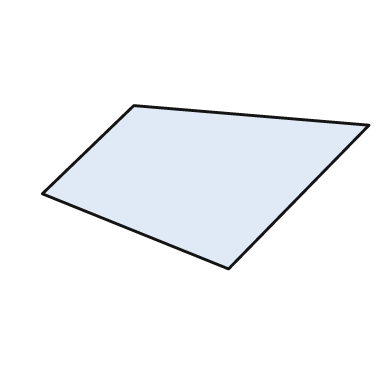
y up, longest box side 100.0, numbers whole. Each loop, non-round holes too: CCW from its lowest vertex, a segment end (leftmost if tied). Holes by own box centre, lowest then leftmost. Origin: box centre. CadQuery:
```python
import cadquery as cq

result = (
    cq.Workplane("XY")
    .moveTo(7.0, -25.0)
    .lineTo(50.0, 19.0)
    .lineTo(-22.0, 25.0)
    .lineTo(-50.0, -2.0)
    .close()
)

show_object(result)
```